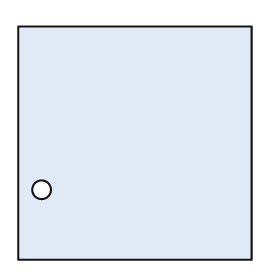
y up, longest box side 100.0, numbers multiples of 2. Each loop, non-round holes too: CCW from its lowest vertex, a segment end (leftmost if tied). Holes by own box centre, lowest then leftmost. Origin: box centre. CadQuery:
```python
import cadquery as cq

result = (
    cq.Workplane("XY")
    .moveTo(-50.0, -50.0)
    .lineTo(50.0, -50.0)
    .lineTo(50.0, 50.0)
    .lineTo(-50.0, 50.0)
    .close()
    .moveTo(-40.0, -20.0)
    .circle(4.0)
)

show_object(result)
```